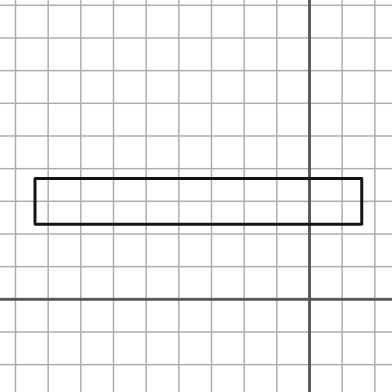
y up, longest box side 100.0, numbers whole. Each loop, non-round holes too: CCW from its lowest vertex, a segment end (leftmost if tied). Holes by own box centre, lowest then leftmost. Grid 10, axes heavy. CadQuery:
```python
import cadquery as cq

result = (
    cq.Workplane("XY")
    .moveTo(-84.0, 23.0)
    .lineTo(16.0, 23.0)
    .lineTo(16.0, 37.0)
    .lineTo(-84.0, 37.0)
    .close()
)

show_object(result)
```